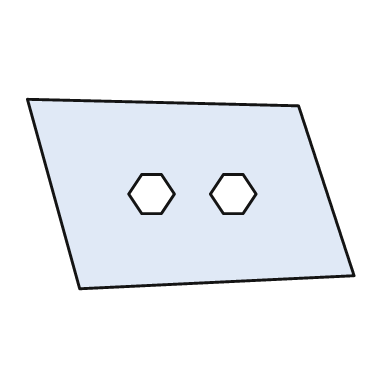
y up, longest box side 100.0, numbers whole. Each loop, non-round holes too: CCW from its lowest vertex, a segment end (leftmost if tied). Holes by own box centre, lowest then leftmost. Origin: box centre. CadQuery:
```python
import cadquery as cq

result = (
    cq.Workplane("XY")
    .moveTo(-34.0, -29.0)
    .lineTo(50.0, -25.0)
    .lineTo(33.0, 27.0)
    .lineTo(-50.0, 29.0)
    .close()
    .moveTo(-15.0, -6.0)
    .lineTo(-9.0, -6.0)
    .lineTo(-5.0, 0.0)
    .lineTo(-9.0, 6.0)
    .lineTo(-15.0, 6.0)
    .lineTo(-19.0, 0.0)
    .close()
    .moveTo(10.0, -6.0)
    .lineTo(16.0, -6.0)
    .lineTo(20.0, 0.0)
    .lineTo(16.0, 6.0)
    .lineTo(10.0, 6.0)
    .lineTo(6.0, 0.0)
    .close()
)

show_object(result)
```